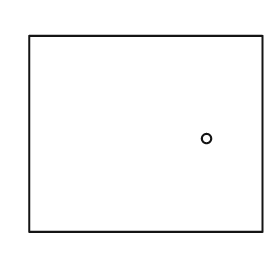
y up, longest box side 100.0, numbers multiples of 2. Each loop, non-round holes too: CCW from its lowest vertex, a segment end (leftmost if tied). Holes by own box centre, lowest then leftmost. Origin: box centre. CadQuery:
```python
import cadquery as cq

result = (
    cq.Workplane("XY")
    .moveTo(-50.0, -42.0)
    .lineTo(50.0, -42.0)
    .lineTo(50.0, 42.0)
    .lineTo(-50.0, 42.0)
    .close()
    .moveTo(26.0, -2.0)
    .circle(2.0)
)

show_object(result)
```